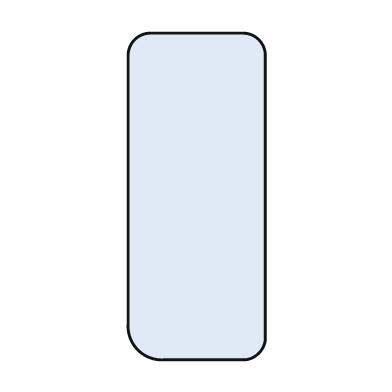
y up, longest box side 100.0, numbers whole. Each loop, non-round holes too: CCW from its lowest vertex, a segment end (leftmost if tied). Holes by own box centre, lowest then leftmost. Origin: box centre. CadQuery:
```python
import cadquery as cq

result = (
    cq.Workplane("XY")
    .moveTo(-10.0, -50.0)
    .lineTo(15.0, -50.0)
    .threePointArc((19.0, -48.0), (21.0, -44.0))
    .lineTo(21.0, 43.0)
    .threePointArc((19.0, 48.0), (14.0, 50.0))
    .lineTo(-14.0, 50.0)
    .threePointArc((-19.0, 48.0), (-21.0, 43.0))
    .lineTo(-21.0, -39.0)
    .threePointArc((-18.0, -47.0), (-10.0, -50.0))
    .close()
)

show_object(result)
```